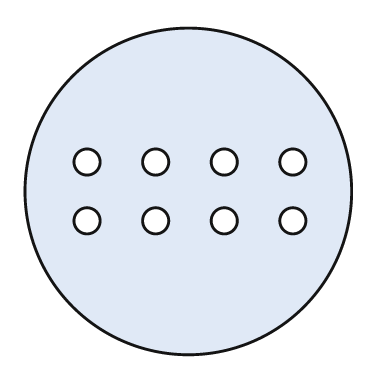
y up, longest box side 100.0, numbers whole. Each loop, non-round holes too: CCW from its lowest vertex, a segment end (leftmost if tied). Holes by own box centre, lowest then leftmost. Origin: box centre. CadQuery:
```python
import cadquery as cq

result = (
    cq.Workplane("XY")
    .moveTo(0.0, 0.0)
    .circle(50.0)
    .moveTo(-31.0, -9.0)
    .circle(4.0)
    .moveTo(-10.0, -9.0)
    .circle(4.0)
    .moveTo(11.0, -9.0)
    .circle(4.0)
    .moveTo(32.0, -9.0)
    .circle(4.0)
    .moveTo(-31.0, 9.0)
    .circle(4.0)
    .moveTo(-10.0, 9.0)
    .circle(4.0)
    .moveTo(11.0, 9.0)
    .circle(4.0)
    .moveTo(32.0, 9.0)
    .circle(4.0)
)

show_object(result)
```